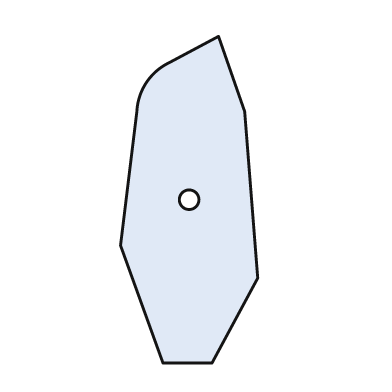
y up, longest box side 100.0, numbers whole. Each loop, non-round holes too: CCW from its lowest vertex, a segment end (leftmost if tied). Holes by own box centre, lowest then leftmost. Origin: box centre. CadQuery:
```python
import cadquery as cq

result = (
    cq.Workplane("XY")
    .moveTo(-8.0, -50.0)
    .lineTo(7.0, -50.0)
    .lineTo(21.0, -24.0)
    .lineTo(17.0, 27.0)
    .lineTo(9.0, 50.0)
    .lineTo(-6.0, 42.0)
    .threePointArc((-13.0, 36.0), (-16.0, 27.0))
    .lineTo(-21.0, -14.0)
    .close()
    .moveTo(0.0, 0.0)
    .circle(3.0)
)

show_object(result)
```